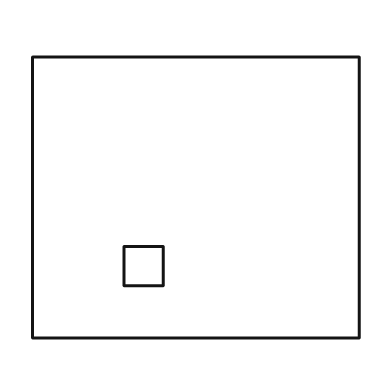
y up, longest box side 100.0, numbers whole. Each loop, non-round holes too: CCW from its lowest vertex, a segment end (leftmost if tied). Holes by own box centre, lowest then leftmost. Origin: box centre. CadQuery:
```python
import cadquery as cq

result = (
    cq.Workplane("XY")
    .moveTo(-50.0, -43.0)
    .lineTo(50.0, -43.0)
    .lineTo(50.0, 43.0)
    .lineTo(-50.0, 43.0)
    .close()
    .moveTo(-22.0, -27.0)
    .lineTo(-10.0, -27.0)
    .lineTo(-10.0, -15.0)
    .lineTo(-22.0, -15.0)
    .close()
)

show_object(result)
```